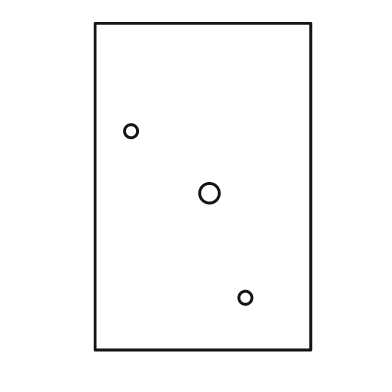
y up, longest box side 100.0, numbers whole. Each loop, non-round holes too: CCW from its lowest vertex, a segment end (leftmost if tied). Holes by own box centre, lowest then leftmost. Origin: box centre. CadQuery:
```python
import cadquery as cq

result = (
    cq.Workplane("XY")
    .moveTo(-33.0, -50.0)
    .lineTo(33.0, -50.0)
    .lineTo(33.0, 50.0)
    .lineTo(-33.0, 50.0)
    .close()
    .moveTo(13.0, -34.0)
    .circle(2.0)
    .moveTo(2.0, -2.0)
    .circle(3.0)
    .moveTo(-22.0, 17.0)
    .circle(2.0)
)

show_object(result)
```